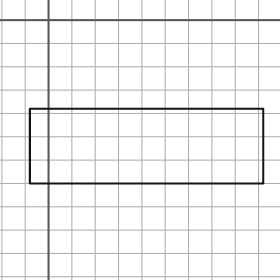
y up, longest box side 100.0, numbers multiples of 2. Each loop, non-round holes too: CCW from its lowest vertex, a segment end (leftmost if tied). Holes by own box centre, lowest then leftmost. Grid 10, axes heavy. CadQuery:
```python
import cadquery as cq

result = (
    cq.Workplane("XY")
    .moveTo(-8.0, -70.0)
    .lineTo(92.0, -70.0)
    .lineTo(92.0, -38.0)
    .lineTo(-8.0, -38.0)
    .close()
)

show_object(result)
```